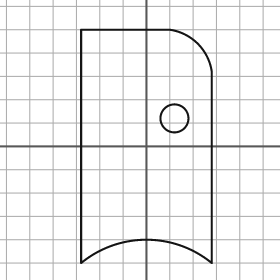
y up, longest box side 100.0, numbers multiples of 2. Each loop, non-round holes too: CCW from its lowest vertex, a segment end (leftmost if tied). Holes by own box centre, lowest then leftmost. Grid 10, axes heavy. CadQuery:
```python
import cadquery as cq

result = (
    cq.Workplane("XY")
    .moveTo(-28.0, -50.0)
    .threePointArc((0.0, -40.0), (28.0, -50.0))
    .lineTo(28.0, 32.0)
    .threePointArc((22.0, 44.0), (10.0, 50.0))
    .lineTo(-28.0, 50.0)
    .close()
    .moveTo(12.0, 12.0)
    .circle(6.0)
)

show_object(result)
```